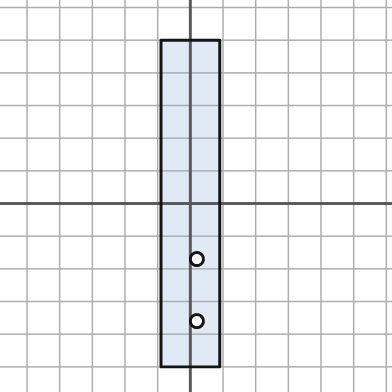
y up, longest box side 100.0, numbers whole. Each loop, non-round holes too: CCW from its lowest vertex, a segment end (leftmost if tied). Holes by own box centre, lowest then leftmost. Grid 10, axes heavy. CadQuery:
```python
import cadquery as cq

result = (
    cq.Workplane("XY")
    .moveTo(-9.0, -50.0)
    .lineTo(9.0, -50.0)
    .lineTo(9.0, 50.0)
    .lineTo(-9.0, 50.0)
    .close()
    .moveTo(2.0, -36.0)
    .circle(2.0)
    .moveTo(2.0, -17.0)
    .circle(2.0)
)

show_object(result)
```